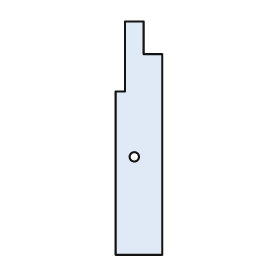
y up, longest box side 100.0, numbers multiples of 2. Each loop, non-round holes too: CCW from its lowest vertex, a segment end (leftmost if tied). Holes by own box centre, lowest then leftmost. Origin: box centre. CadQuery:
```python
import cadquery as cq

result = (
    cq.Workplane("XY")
    .moveTo(-10.0, -50.0)
    .lineTo(10.0, -50.0)
    .lineTo(10.0, 36.0)
    .lineTo(2.0, 36.0)
    .lineTo(2.0, 50.0)
    .lineTo(-6.0, 50.0)
    .lineTo(-6.0, 20.0)
    .lineTo(-10.0, 20.0)
    .close()
    .moveTo(-2.0, -8.0)
    .circle(2.0)
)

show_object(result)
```